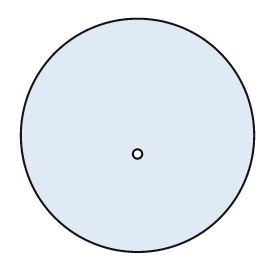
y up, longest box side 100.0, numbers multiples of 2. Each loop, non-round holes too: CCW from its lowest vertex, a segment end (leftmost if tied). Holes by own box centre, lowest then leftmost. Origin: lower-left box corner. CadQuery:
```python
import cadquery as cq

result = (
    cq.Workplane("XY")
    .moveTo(50.0, 50.0)
    .circle(50.0)
    .moveTo(50.0, 42.0)
    .circle(2.0)
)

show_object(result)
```